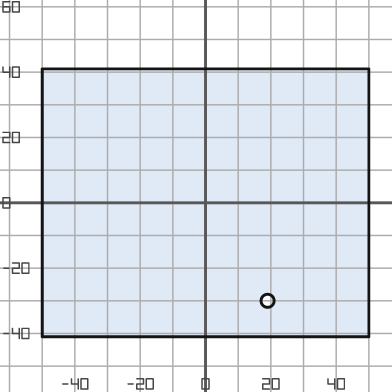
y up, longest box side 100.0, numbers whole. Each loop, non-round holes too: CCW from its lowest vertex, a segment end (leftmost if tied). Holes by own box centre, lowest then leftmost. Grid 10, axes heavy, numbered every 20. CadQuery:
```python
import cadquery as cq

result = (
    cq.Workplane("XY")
    .moveTo(-50.0, -41.0)
    .lineTo(50.0, -41.0)
    .lineTo(50.0, 41.0)
    .lineTo(-50.0, 41.0)
    .close()
    .moveTo(19.0, -30.0)
    .circle(2.0)
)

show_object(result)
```